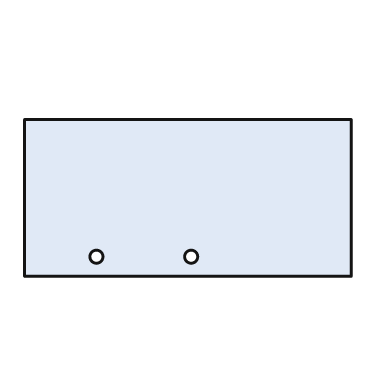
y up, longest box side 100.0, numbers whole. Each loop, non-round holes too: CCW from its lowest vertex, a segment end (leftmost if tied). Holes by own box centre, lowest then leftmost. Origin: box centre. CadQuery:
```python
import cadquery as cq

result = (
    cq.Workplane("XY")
    .moveTo(-50.0, -24.0)
    .lineTo(50.0, -24.0)
    .lineTo(50.0, 24.0)
    .lineTo(-50.0, 24.0)
    .close()
    .moveTo(-28.0, -18.0)
    .circle(2.0)
    .moveTo(1.0, -18.0)
    .circle(2.0)
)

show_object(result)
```